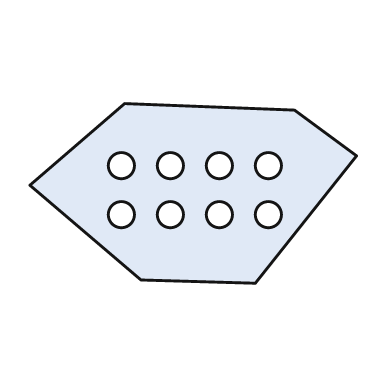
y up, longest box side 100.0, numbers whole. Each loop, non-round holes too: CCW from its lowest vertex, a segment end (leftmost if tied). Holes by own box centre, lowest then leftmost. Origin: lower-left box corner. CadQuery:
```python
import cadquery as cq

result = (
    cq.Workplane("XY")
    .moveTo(69.0, 0.0)
    .lineTo(100.0, 39.0)
    .lineTo(81.0, 53.0)
    .lineTo(29.0, 55.0)
    .lineTo(0.0, 30.0)
    .lineTo(34.0, 1.0)
    .close()
    .moveTo(28.0, 21.0)
    .circle(4.0)
    .moveTo(43.0, 21.0)
    .circle(4.0)
    .moveTo(58.0, 21.0)
    .circle(4.0)
    .moveTo(73.0, 21.0)
    .circle(4.0)
    .moveTo(28.0, 36.0)
    .circle(4.0)
    .moveTo(43.0, 36.0)
    .circle(4.0)
    .moveTo(58.0, 36.0)
    .circle(4.0)
    .moveTo(73.0, 36.0)
    .circle(4.0)
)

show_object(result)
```